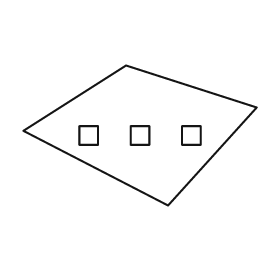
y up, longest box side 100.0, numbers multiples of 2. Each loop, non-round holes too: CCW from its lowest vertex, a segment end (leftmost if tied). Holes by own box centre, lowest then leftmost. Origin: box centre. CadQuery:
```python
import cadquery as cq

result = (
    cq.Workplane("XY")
    .moveTo(12.0, -30.0)
    .lineTo(50.0, 12.0)
    .lineTo(-6.0, 30.0)
    .lineTo(-50.0, 2.0)
    .close()
    .moveTo(-26.0, -4.0)
    .lineTo(-18.0, -4.0)
    .lineTo(-18.0, 4.0)
    .lineTo(-26.0, 4.0)
    .close()
    .moveTo(-4.0, -4.0)
    .lineTo(4.0, -4.0)
    .lineTo(4.0, 4.0)
    .lineTo(-4.0, 4.0)
    .close()
    .moveTo(18.0, -4.0)
    .lineTo(26.0, -4.0)
    .lineTo(26.0, 4.0)
    .lineTo(18.0, 4.0)
    .close()
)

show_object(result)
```